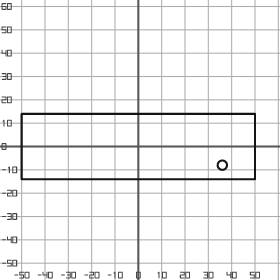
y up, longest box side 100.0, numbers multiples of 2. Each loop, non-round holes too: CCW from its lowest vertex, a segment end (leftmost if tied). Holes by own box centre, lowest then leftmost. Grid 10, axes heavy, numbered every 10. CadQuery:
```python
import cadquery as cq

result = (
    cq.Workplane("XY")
    .moveTo(-50.0, -14.0)
    .lineTo(50.0, -14.0)
    .lineTo(50.0, 14.0)
    .lineTo(-50.0, 14.0)
    .close()
    .moveTo(36.0, -8.0)
    .circle(2.0)
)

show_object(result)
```